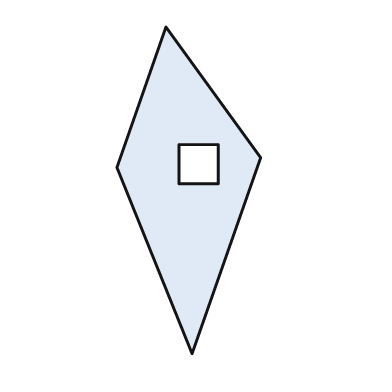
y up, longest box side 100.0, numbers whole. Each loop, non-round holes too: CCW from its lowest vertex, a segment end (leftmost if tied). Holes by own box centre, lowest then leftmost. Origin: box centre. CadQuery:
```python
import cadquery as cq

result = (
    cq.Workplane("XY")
    .moveTo(1.0, -50.0)
    .lineTo(22.0, 10.0)
    .lineTo(-7.0, 50.0)
    .lineTo(-22.0, 7.0)
    .close()
    .moveTo(-3.0, 2.0)
    .lineTo(9.0, 2.0)
    .lineTo(9.0, 14.0)
    .lineTo(-3.0, 14.0)
    .close()
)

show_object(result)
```